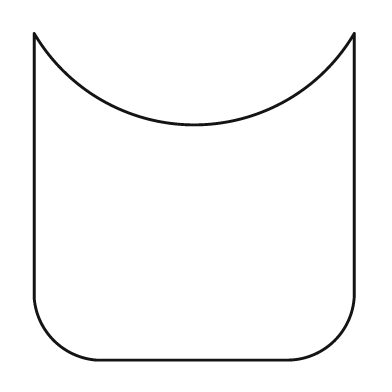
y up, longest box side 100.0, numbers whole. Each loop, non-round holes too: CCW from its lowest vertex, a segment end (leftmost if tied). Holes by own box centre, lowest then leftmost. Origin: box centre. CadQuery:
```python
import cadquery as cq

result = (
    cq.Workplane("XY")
    .moveTo(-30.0, -50.0)
    .lineTo(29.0, -50.0)
    .threePointArc((43.0, -44.0), (49.0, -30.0))
    .lineTo(49.0, 50.0)
    .threePointArc((0.0, 22.0), (-49.0, 50.0))
    .lineTo(-49.0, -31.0)
    .threePointArc((-43.0, -44.0), (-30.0, -50.0))
    .close()
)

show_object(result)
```